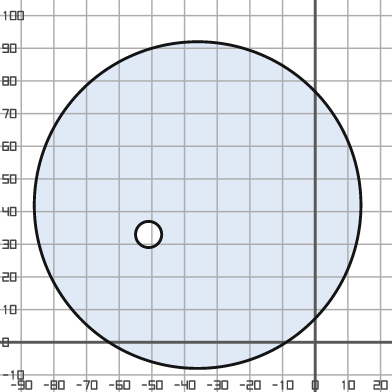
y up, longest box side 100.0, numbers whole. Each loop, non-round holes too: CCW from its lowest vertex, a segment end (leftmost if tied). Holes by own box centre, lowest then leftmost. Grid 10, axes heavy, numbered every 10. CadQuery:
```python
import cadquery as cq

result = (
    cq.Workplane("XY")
    .moveTo(-36.0, 42.0)
    .circle(50.0)
    .moveTo(-51.0, 33.0)
    .circle(4.0)
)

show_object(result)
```